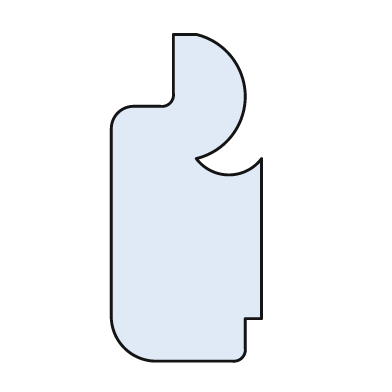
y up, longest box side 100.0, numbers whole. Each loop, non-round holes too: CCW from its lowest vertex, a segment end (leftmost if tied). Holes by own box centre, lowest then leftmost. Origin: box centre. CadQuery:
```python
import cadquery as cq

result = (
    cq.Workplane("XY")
    .moveTo(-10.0, -50.0)
    .lineTo(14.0, -50.0)
    .threePointArc((17.0, -49.0), (18.0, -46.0))
    .lineTo(18.0, -37.0)
    .lineTo(23.0, -37.0)
    .lineTo(23.0, 12.0)
    .threePointArc((13.0, 7.0), (3.0, 12.0))
    .threePointArc((18.0, 31.0), (3.0, 50.0))
    .lineTo(-4.0, 50.0)
    .lineTo(-4.0, 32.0)
    .threePointArc((-5.0, 29.0), (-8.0, 28.0))
    .lineTo(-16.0, 28.0)
    .threePointArc((-21.0, 26.0), (-23.0, 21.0))
    .lineTo(-23.0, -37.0)
    .threePointArc((-19.0, -46.0), (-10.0, -50.0))
    .close()
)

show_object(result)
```